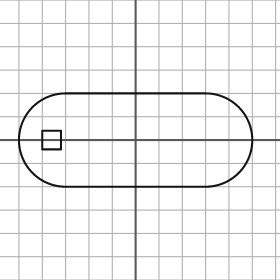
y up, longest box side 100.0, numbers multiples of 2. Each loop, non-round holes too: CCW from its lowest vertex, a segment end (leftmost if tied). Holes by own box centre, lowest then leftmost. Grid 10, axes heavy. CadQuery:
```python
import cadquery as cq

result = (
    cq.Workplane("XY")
    .moveTo(-30.0, -20.0)
    .lineTo(30.0, -20.0)
    .threePointArc((50.0, 0.0), (30.0, 20.0))
    .lineTo(-30.0, 20.0)
    .threePointArc((-50.0, 0.0), (-30.0, -20.0))
    .close()
    .moveTo(-40.0, -4.0)
    .lineTo(-32.0, -4.0)
    .lineTo(-32.0, 4.0)
    .lineTo(-40.0, 4.0)
    .close()
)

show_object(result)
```